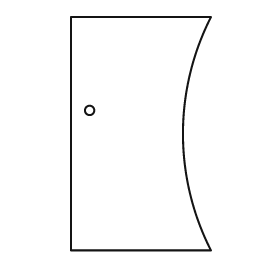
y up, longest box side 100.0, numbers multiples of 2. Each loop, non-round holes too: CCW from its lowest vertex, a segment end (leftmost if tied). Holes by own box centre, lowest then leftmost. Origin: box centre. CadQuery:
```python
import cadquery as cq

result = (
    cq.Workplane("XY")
    .moveTo(-30.0, -50.0)
    .lineTo(30.0, -50.0)
    .threePointArc((18.0, 0.0), (30.0, 50.0))
    .lineTo(-30.0, 50.0)
    .close()
    .moveTo(-22.0, 10.0)
    .circle(2.0)
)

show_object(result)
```